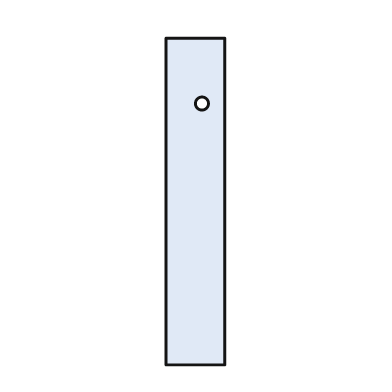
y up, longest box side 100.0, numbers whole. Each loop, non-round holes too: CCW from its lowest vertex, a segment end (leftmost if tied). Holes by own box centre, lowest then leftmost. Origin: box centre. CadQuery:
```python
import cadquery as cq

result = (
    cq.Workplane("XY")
    .moveTo(-9.0, -50.0)
    .lineTo(9.0, -50.0)
    .lineTo(9.0, 50.0)
    .lineTo(-9.0, 50.0)
    .close()
    .moveTo(2.0, 30.0)
    .circle(2.0)
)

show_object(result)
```